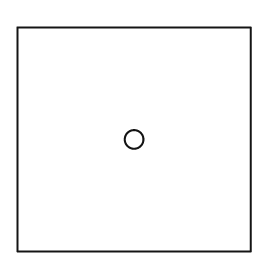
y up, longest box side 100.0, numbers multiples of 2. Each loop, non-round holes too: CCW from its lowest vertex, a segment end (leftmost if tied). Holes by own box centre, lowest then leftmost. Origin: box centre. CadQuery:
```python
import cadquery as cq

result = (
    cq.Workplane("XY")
    .moveTo(-50.0, -48.0)
    .lineTo(50.0, -48.0)
    .lineTo(50.0, 48.0)
    .lineTo(-50.0, 48.0)
    .close()
    .moveTo(0.0, 0.0)
    .circle(4.0)
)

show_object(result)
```